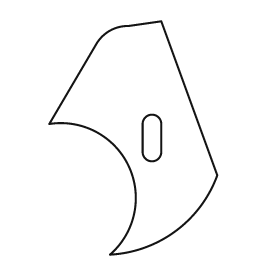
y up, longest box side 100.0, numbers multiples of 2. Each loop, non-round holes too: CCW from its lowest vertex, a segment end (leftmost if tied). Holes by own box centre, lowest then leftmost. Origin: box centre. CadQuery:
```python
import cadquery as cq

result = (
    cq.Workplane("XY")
    .moveTo(-10.0, -50.0)
    .threePointArc((18.0, -40.0), (36.0, -16.0))
    .lineTo(12.0, 50.0)
    .lineTo(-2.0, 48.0)
    .threePointArc((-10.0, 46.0), (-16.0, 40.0))
    .lineTo(-36.0, 6.0)
    .threePointArc((-2.0, -12.0), (-10.0, -50.0))
    .close()
    .moveTo(4.0, -6.0)
    .threePointArc((8.0, -10.0), (12.0, -6.0))
    .lineTo(12.0, 6.0)
    .threePointArc((8.0, 10.0), (4.0, 6.0))
    .close()
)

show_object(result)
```